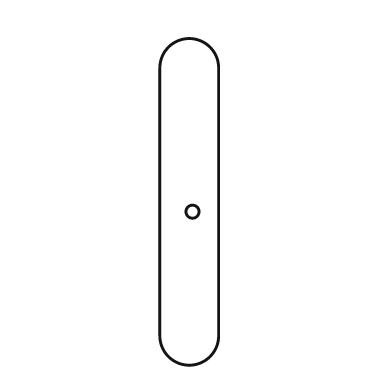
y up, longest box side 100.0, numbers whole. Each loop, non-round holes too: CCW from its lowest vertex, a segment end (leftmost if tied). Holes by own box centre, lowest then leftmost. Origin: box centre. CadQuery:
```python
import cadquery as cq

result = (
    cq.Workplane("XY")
    .moveTo(-9.0, -41.0)
    .threePointArc((0.0, -50.0), (9.0, -41.0))
    .lineTo(9.0, 41.0)
    .threePointArc((0.0, 50.0), (-9.0, 41.0))
    .close()
    .moveTo(1.0, -3.0)
    .circle(2.0)
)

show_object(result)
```